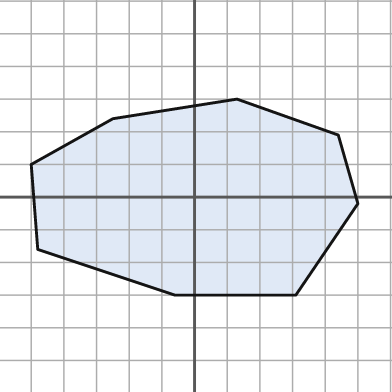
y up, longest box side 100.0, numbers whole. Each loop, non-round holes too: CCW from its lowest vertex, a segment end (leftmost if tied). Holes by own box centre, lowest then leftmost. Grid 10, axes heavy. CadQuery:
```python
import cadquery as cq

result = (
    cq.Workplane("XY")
    .moveTo(-6.0, -30.0)
    .lineTo(31.0, -30.0)
    .lineTo(50.0, -2.0)
    .lineTo(44.0, 19.0)
    .lineTo(13.0, 30.0)
    .lineTo(-25.0, 24.0)
    .lineTo(-50.0, 10.0)
    .lineTo(-48.0, -16.0)
    .close()
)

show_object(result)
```